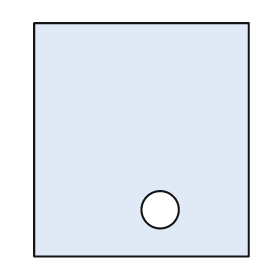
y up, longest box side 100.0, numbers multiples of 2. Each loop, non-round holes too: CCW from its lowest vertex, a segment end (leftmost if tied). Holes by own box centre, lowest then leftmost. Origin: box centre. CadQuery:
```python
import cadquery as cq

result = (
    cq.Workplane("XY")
    .moveTo(-46.0, -50.0)
    .lineTo(46.0, -50.0)
    .lineTo(46.0, 50.0)
    .lineTo(-46.0, 50.0)
    .close()
    .moveTo(8.0, -30.0)
    .circle(8.0)
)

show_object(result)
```